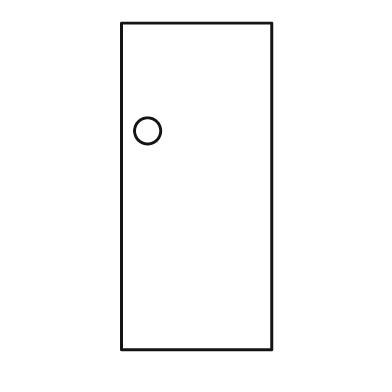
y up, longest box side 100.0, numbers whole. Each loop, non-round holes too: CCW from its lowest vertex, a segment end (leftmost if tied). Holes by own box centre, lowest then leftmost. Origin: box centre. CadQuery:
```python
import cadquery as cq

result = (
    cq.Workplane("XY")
    .moveTo(-23.0, -50.0)
    .lineTo(23.0, -50.0)
    .lineTo(23.0, 50.0)
    .lineTo(-23.0, 50.0)
    .close()
    .moveTo(-15.0, 17.0)
    .circle(4.0)
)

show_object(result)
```